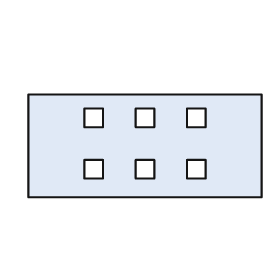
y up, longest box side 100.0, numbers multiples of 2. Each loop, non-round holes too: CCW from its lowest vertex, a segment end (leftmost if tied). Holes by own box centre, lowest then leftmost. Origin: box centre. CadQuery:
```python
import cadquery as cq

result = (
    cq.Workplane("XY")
    .moveTo(-50.0, -22.0)
    .lineTo(50.0, -22.0)
    .lineTo(50.0, 22.0)
    .lineTo(-50.0, 22.0)
    .close()
    .moveTo(-26.0, -14.0)
    .lineTo(-18.0, -14.0)
    .lineTo(-18.0, -6.0)
    .lineTo(-26.0, -6.0)
    .close()
    .moveTo(-4.0, -14.0)
    .lineTo(4.0, -14.0)
    .lineTo(4.0, -6.0)
    .lineTo(-4.0, -6.0)
    .close()
    .moveTo(18.0, -14.0)
    .lineTo(26.0, -14.0)
    .lineTo(26.0, -6.0)
    .lineTo(18.0, -6.0)
    .close()
    .moveTo(-26.0, 8.0)
    .lineTo(-18.0, 8.0)
    .lineTo(-18.0, 16.0)
    .lineTo(-26.0, 16.0)
    .close()
    .moveTo(-4.0, 8.0)
    .lineTo(4.0, 8.0)
    .lineTo(4.0, 16.0)
    .lineTo(-4.0, 16.0)
    .close()
    .moveTo(18.0, 8.0)
    .lineTo(26.0, 8.0)
    .lineTo(26.0, 16.0)
    .lineTo(18.0, 16.0)
    .close()
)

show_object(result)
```